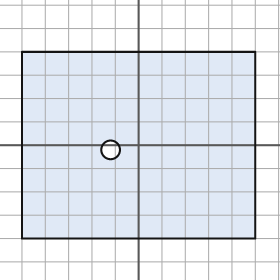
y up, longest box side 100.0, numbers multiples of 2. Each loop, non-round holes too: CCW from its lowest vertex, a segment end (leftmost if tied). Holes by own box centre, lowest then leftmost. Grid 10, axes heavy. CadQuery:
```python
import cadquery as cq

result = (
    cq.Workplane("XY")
    .moveTo(-50.0, -40.0)
    .lineTo(50.0, -40.0)
    .lineTo(50.0, 40.0)
    .lineTo(-50.0, 40.0)
    .close()
    .moveTo(-12.0, -2.0)
    .circle(4.0)
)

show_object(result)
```